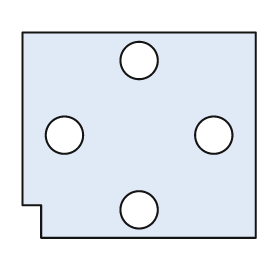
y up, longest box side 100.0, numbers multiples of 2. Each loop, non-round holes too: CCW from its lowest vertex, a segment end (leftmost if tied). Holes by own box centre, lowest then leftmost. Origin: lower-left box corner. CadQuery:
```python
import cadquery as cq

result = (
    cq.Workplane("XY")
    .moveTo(8.0, 0.0)
    .lineTo(100.0, 0.0)
    .lineTo(100.0, 88.0)
    .lineTo(0.0, 88.0)
    .lineTo(0.0, 14.0)
    .lineTo(8.0, 14.0)
    .close()
    .moveTo(50.0, 12.0)
    .circle(8.0)
    .moveTo(18.0, 44.0)
    .circle(8.0)
    .moveTo(82.0, 44.0)
    .circle(8.0)
    .moveTo(50.0, 76.0)
    .circle(8.0)
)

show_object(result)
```